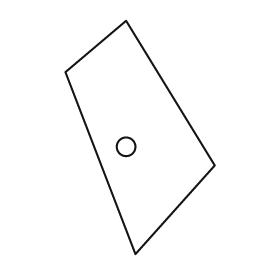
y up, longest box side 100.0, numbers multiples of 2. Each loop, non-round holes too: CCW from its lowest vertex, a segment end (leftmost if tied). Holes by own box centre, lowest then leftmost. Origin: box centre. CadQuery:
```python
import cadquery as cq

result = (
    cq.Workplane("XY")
    .moveTo(-2.0, -50.0)
    .lineTo(32.0, -12.0)
    .lineTo(-6.0, 50.0)
    .lineTo(-32.0, 28.0)
    .close()
    .moveTo(-6.0, -4.0)
    .circle(4.0)
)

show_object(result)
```